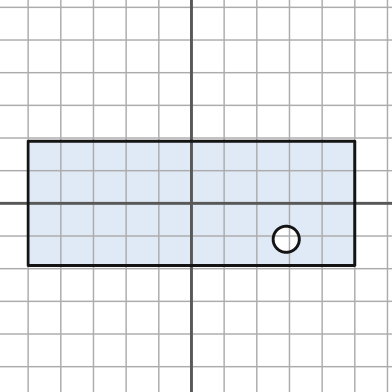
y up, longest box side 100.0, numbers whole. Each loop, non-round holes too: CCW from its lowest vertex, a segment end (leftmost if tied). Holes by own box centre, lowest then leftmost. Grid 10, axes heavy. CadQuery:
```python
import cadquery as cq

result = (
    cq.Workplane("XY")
    .moveTo(-50.0, -19.0)
    .lineTo(50.0, -19.0)
    .lineTo(50.0, 19.0)
    .lineTo(-50.0, 19.0)
    .close()
    .moveTo(29.0, -11.0)
    .circle(4.0)
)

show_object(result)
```